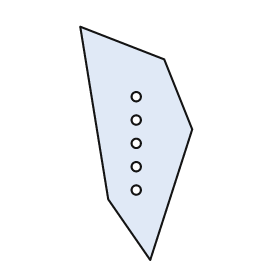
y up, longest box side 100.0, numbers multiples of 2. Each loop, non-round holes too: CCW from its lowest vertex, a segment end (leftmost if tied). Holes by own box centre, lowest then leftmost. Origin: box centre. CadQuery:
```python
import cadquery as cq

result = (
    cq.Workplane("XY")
    .moveTo(6.0, -50.0)
    .lineTo(24.0, 6.0)
    .lineTo(12.0, 36.0)
    .lineTo(-24.0, 50.0)
    .lineTo(-12.0, -24.0)
    .close()
    .moveTo(0.0, -20.0)
    .circle(2.0)
    .moveTo(0.0, -10.0)
    .circle(2.0)
    .moveTo(0.0, 0.0)
    .circle(2.0)
    .moveTo(0.0, 10.0)
    .circle(2.0)
    .moveTo(0.0, 20.0)
    .circle(2.0)
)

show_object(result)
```